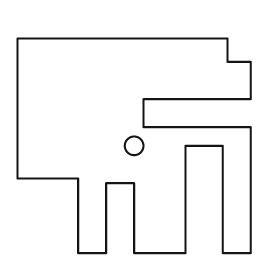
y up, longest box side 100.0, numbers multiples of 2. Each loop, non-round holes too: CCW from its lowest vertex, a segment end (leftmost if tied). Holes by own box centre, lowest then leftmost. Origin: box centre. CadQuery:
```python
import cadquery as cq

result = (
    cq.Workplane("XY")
    .moveTo(-24.0, -46.0)
    .lineTo(-12.0, -46.0)
    .lineTo(-12.0, -16.0)
    .lineTo(0.0, -16.0)
    .lineTo(0.0, -46.0)
    .lineTo(22.0, -46.0)
    .lineTo(22.0, 0.0)
    .lineTo(38.0, 0.0)
    .lineTo(38.0, -46.0)
    .lineTo(50.0, -46.0)
    .lineTo(50.0, 8.0)
    .lineTo(4.0, 8.0)
    .lineTo(4.0, 20.0)
    .lineTo(50.0, 20.0)
    .lineTo(50.0, 36.0)
    .lineTo(40.0, 36.0)
    .lineTo(40.0, 46.0)
    .lineTo(-50.0, 46.0)
    .lineTo(-50.0, -14.0)
    .lineTo(-24.0, -14.0)
    .close()
    .moveTo(0.0, 0.0)
    .circle(4.0)
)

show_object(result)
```